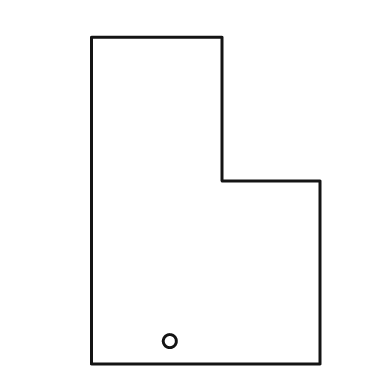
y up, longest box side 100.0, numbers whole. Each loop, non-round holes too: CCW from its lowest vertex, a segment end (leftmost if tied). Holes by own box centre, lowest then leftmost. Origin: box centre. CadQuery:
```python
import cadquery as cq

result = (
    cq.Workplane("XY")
    .moveTo(-35.0, -50.0)
    .lineTo(35.0, -50.0)
    .lineTo(35.0, 6.0)
    .lineTo(5.0, 6.0)
    .lineTo(5.0, 50.0)
    .lineTo(-35.0, 50.0)
    .close()
    .moveTo(-11.0, -43.0)
    .circle(2.0)
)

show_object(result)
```